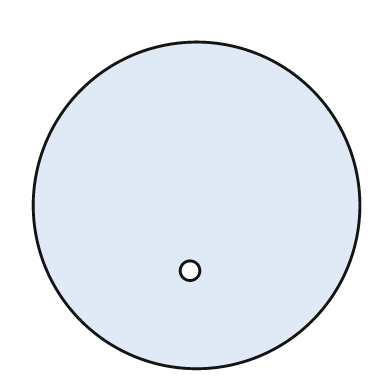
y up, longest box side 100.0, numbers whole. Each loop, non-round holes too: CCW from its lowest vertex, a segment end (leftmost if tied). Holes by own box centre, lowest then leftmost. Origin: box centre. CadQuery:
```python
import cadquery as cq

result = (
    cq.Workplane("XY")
    .moveTo(0.0, 0.0)
    .circle(50.0)
    .moveTo(-2.0, -20.0)
    .circle(3.0)
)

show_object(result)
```